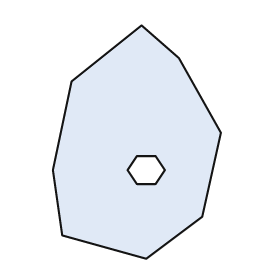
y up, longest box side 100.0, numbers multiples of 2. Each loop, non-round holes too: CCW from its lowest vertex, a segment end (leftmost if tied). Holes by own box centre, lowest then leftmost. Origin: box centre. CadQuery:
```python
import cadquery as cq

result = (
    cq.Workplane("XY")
    .moveTo(4.0, -50.0)
    .lineTo(28.0, -32.0)
    .lineTo(36.0, 4.0)
    .lineTo(18.0, 36.0)
    .lineTo(2.0, 50.0)
    .lineTo(-28.0, 26.0)
    .lineTo(-36.0, -12.0)
    .lineTo(-32.0, -40.0)
    .close()
    .moveTo(0.0, -18.0)
    .lineTo(8.0, -18.0)
    .lineTo(12.0, -12.0)
    .lineTo(8.0, -6.0)
    .lineTo(0.0, -6.0)
    .lineTo(-4.0, -12.0)
    .close()
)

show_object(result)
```